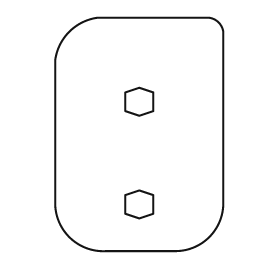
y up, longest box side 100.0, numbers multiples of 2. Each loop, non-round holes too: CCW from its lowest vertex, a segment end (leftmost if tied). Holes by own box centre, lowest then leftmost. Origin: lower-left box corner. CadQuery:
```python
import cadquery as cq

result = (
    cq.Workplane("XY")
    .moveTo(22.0, 0.0)
    .lineTo(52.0, 0.0)
    .threePointArc((66.0, 6.0), (72.0, 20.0))
    .lineTo(72.0, 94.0)
    .threePointArc((70.0, 98.0), (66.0, 100.0))
    .lineTo(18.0, 100.0)
    .threePointArc((6.0, 94.0), (0.0, 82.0))
    .lineTo(0.0, 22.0)
    .threePointArc((6.0, 6.0), (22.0, 0.0))
    .close()
    .moveTo(36.0, 14.0)
    .lineTo(42.0, 16.0)
    .lineTo(42.0, 24.0)
    .lineTo(36.0, 26.0)
    .lineTo(30.0, 24.0)
    .lineTo(30.0, 16.0)
    .close()
    .moveTo(36.0, 58.0)
    .lineTo(42.0, 60.0)
    .lineTo(42.0, 68.0)
    .lineTo(36.0, 70.0)
    .lineTo(30.0, 68.0)
    .lineTo(30.0, 60.0)
    .close()
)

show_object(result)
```